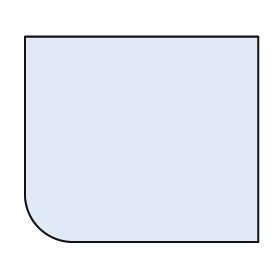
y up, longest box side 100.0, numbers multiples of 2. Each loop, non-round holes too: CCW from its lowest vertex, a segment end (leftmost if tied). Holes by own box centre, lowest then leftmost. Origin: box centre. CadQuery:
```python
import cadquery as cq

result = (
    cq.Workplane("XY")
    .moveTo(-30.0, -44.0)
    .lineTo(50.0, -44.0)
    .lineTo(50.0, 44.0)
    .lineTo(-50.0, 44.0)
    .lineTo(-50.0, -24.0)
    .threePointArc((-44.0, -38.0), (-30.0, -44.0))
    .close()
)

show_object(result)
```